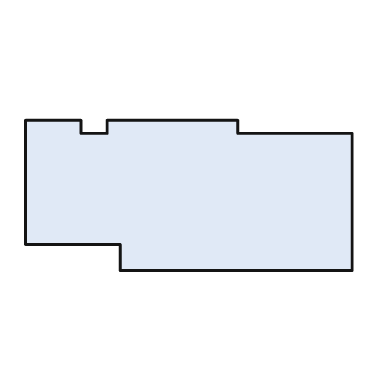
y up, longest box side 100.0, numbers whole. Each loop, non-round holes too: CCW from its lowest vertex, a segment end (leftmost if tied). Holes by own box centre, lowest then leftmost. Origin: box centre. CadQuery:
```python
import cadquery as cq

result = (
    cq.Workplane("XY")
    .moveTo(-21.0, -23.0)
    .lineTo(50.0, -23.0)
    .lineTo(50.0, 19.0)
    .lineTo(15.0, 19.0)
    .lineTo(15.0, 23.0)
    .lineTo(-25.0, 23.0)
    .lineTo(-25.0, 19.0)
    .lineTo(-33.0, 19.0)
    .lineTo(-33.0, 23.0)
    .lineTo(-50.0, 23.0)
    .lineTo(-50.0, -15.0)
    .lineTo(-21.0, -15.0)
    .close()
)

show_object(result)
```